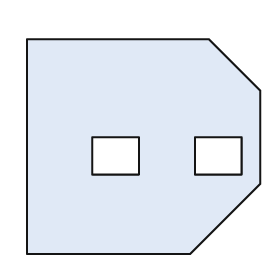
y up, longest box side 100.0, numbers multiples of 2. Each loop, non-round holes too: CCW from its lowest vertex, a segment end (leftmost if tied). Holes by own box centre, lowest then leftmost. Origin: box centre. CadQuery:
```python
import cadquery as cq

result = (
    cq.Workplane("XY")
    .moveTo(-50.0, -46.0)
    .lineTo(20.0, -46.0)
    .lineTo(50.0, -16.0)
    .lineTo(50.0, 24.0)
    .lineTo(28.0, 46.0)
    .lineTo(-50.0, 46.0)
    .close()
    .moveTo(-22.0, -12.0)
    .lineTo(-2.0, -12.0)
    .lineTo(-2.0, 4.0)
    .lineTo(-22.0, 4.0)
    .close()
    .moveTo(22.0, -12.0)
    .lineTo(42.0, -12.0)
    .lineTo(42.0, 4.0)
    .lineTo(22.0, 4.0)
    .close()
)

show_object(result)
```